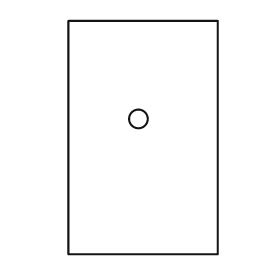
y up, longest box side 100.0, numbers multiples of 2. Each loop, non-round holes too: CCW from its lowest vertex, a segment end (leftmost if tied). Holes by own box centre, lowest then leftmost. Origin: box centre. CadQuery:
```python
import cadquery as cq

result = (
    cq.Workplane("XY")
    .moveTo(-32.0, -50.0)
    .lineTo(32.0, -50.0)
    .lineTo(32.0, 50.0)
    .lineTo(-32.0, 50.0)
    .close()
    .moveTo(-2.0, 8.0)
    .circle(4.0)
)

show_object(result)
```